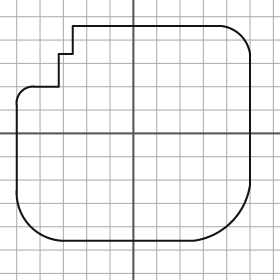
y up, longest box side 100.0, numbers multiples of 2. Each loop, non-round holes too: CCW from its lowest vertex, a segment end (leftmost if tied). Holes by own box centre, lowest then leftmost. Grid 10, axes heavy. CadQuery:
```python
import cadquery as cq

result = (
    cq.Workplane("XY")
    .moveTo(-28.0, -46.0)
    .lineTo(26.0, -46.0)
    .threePointArc((42.0, -38.0), (50.0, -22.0))
    .lineTo(50.0, 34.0)
    .threePointArc((46.0, 42.0), (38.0, 46.0))
    .lineTo(-26.0, 46.0)
    .lineTo(-26.0, 34.0)
    .lineTo(-32.0, 34.0)
    .lineTo(-32.0, 20.0)
    .lineTo(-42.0, 20.0)
    .threePointArc((-48.0, 18.0), (-50.0, 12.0))
    .lineTo(-50.0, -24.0)
    .threePointArc((-44.0, -40.0), (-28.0, -46.0))
    .close()
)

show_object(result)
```